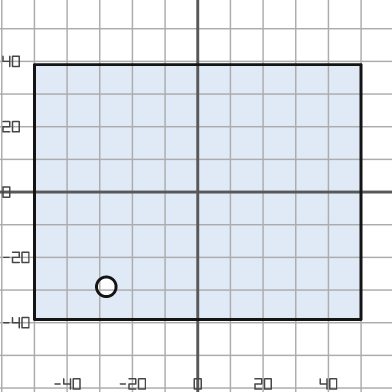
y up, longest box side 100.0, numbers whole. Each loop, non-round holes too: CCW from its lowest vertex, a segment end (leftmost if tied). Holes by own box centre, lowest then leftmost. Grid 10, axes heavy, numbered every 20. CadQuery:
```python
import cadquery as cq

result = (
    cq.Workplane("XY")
    .moveTo(-50.0, -39.0)
    .lineTo(50.0, -39.0)
    .lineTo(50.0, 39.0)
    .lineTo(-50.0, 39.0)
    .close()
    .moveTo(-28.0, -29.0)
    .circle(3.0)
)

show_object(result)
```